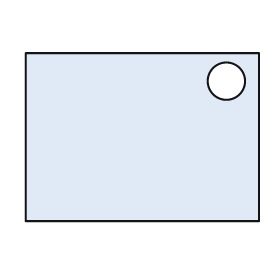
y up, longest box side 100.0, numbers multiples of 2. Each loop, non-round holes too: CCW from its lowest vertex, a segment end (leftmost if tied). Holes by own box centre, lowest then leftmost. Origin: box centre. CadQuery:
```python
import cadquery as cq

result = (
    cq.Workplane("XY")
    .moveTo(-50.0, -36.0)
    .lineTo(50.0, -36.0)
    .lineTo(50.0, 36.0)
    .lineTo(-50.0, 36.0)
    .close()
    .moveTo(36.0, 24.0)
    .circle(8.0)
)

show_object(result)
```